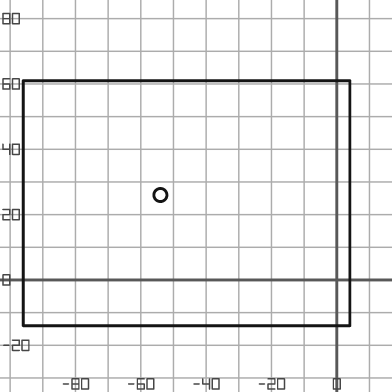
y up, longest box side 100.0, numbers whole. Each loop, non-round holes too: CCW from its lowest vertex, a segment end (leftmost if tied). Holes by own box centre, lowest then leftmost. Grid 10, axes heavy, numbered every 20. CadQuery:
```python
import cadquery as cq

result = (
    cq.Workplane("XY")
    .moveTo(-96.0, -14.0)
    .lineTo(4.0, -14.0)
    .lineTo(4.0, 61.0)
    .lineTo(-96.0, 61.0)
    .close()
    .moveTo(-54.0, 26.0)
    .circle(2.0)
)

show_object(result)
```